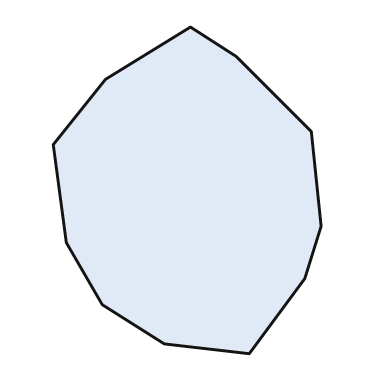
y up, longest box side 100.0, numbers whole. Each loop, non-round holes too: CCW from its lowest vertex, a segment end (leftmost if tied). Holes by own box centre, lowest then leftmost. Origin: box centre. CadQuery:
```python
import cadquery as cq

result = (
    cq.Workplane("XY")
    .moveTo(19.0, -50.0)
    .lineTo(36.0, -27.0)
    .lineTo(41.0, -11.0)
    .lineTo(38.0, 18.0)
    .lineTo(15.0, 41.0)
    .lineTo(1.0, 50.0)
    .lineTo(-25.0, 34.0)
    .lineTo(-41.0, 14.0)
    .lineTo(-37.0, -16.0)
    .lineTo(-26.0, -35.0)
    .lineTo(-7.0, -47.0)
    .close()
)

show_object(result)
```